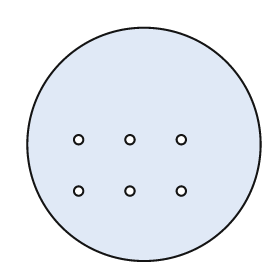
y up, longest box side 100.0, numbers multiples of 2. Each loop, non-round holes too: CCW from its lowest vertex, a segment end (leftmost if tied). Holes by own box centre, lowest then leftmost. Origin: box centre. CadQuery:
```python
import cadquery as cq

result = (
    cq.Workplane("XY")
    .moveTo(0.0, 0.0)
    .circle(50.0)
    .moveTo(-28.0, -20.0)
    .circle(2.0)
    .moveTo(-6.0, -20.0)
    .circle(2.0)
    .moveTo(16.0, -20.0)
    .circle(2.0)
    .moveTo(-28.0, 2.0)
    .circle(2.0)
    .moveTo(-6.0, 2.0)
    .circle(2.0)
    .moveTo(16.0, 2.0)
    .circle(2.0)
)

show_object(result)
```